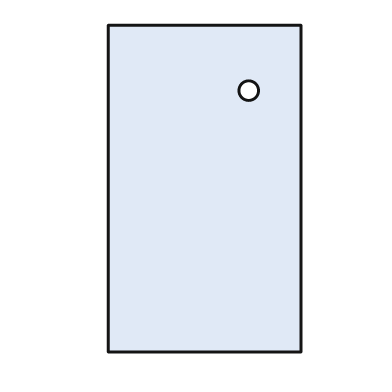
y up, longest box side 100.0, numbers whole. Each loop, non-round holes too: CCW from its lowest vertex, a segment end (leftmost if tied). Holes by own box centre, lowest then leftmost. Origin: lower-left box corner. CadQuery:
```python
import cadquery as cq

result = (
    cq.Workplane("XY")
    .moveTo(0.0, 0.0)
    .lineTo(59.0, 0.0)
    .lineTo(59.0, 100.0)
    .lineTo(0.0, 100.0)
    .close()
    .moveTo(43.0, 80.0)
    .circle(3.0)
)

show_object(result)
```